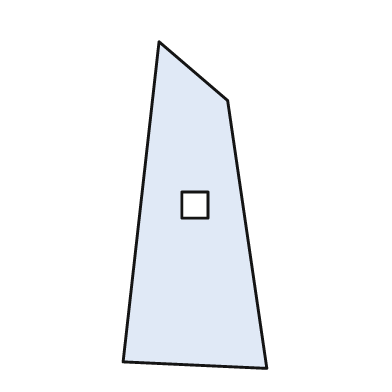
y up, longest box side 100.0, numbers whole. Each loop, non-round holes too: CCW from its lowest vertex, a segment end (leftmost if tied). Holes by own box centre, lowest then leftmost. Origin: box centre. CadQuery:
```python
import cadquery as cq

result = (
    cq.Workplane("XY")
    .moveTo(22.0, -50.0)
    .lineTo(10.0, 32.0)
    .lineTo(-11.0, 50.0)
    .lineTo(-22.0, -48.0)
    .close()
    .moveTo(-4.0, -4.0)
    .lineTo(4.0, -4.0)
    .lineTo(4.0, 4.0)
    .lineTo(-4.0, 4.0)
    .close()
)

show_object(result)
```